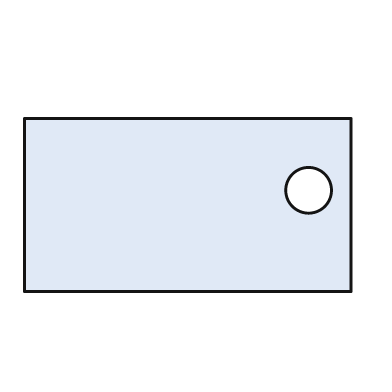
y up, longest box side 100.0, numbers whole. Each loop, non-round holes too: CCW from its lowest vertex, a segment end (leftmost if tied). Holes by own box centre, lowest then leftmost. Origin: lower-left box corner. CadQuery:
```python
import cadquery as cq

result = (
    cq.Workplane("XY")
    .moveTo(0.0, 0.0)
    .lineTo(100.0, 0.0)
    .lineTo(100.0, 53.0)
    .lineTo(0.0, 53.0)
    .close()
    .moveTo(87.0, 31.0)
    .circle(7.0)
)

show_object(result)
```